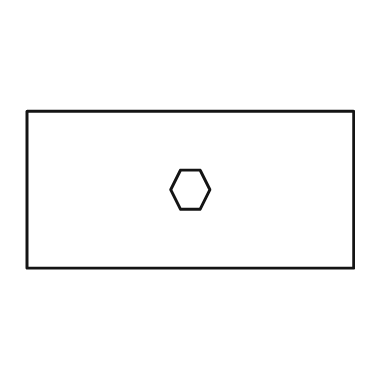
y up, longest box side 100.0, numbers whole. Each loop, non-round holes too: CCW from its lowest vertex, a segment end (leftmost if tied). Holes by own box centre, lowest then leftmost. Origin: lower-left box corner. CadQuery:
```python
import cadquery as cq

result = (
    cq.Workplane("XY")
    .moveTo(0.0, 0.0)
    .lineTo(100.0, 0.0)
    .lineTo(100.0, 48.0)
    .lineTo(0.0, 48.0)
    .close()
    .moveTo(47.0, 18.0)
    .lineTo(53.0, 18.0)
    .lineTo(56.0, 24.0)
    .lineTo(53.0, 30.0)
    .lineTo(47.0, 30.0)
    .lineTo(44.0, 24.0)
    .close()
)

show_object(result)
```